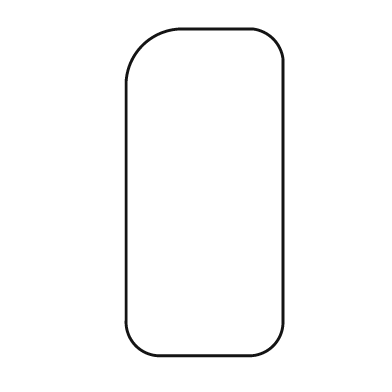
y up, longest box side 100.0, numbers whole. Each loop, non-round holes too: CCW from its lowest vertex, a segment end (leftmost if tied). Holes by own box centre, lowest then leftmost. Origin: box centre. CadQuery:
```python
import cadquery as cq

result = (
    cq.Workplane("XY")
    .moveTo(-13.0, -50.0)
    .lineTo(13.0, -50.0)
    .threePointArc((21.0, -47.0), (24.0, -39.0))
    .lineTo(24.0, 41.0)
    .threePointArc((21.0, 47.0), (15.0, 50.0))
    .lineTo(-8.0, 50.0)
    .threePointArc((-19.0, 45.0), (-24.0, 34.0))
    .lineTo(-24.0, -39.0)
    .threePointArc((-21.0, -47.0), (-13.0, -50.0))
    .close()
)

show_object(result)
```